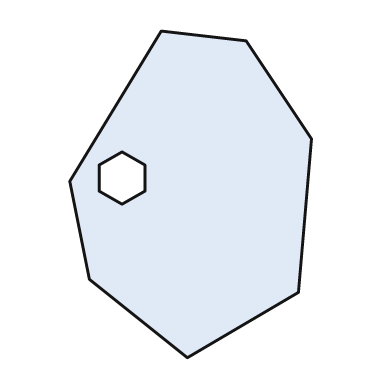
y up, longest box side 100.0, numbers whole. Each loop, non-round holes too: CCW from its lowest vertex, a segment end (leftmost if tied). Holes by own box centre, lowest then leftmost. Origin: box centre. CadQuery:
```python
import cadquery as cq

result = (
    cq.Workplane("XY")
    .moveTo(-1.0, -50.0)
    .lineTo(33.0, -30.0)
    .lineTo(37.0, 17.0)
    .lineTo(17.0, 47.0)
    .lineTo(-9.0, 50.0)
    .lineTo(-37.0, 4.0)
    .lineTo(-31.0, -26.0)
    .close()
    .moveTo(-21.0, -3.0)
    .lineTo(-14.0, 1.0)
    .lineTo(-14.0, 9.0)
    .lineTo(-21.0, 13.0)
    .lineTo(-28.0, 9.0)
    .lineTo(-28.0, 1.0)
    .close()
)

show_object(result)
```